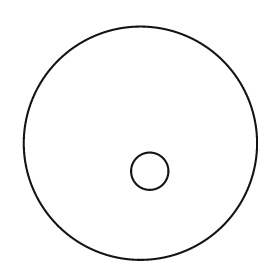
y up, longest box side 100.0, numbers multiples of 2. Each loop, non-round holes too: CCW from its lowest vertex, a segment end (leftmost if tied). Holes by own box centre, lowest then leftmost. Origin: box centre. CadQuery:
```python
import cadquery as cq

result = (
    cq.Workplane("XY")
    .moveTo(0.0, 0.0)
    .circle(50.0)
    .moveTo(4.0, -12.0)
    .circle(8.0)
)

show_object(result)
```